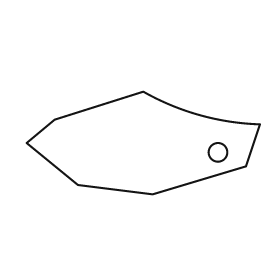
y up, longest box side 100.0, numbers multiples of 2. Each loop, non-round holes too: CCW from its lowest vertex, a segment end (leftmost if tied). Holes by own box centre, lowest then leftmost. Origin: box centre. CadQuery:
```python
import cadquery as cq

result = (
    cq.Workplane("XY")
    .moveTo(4.0, -22.0)
    .lineTo(44.0, -10.0)
    .lineTo(50.0, 8.0)
    .threePointArc((24.0, 12.0), (0.0, 22.0))
    .lineTo(-38.0, 10.0)
    .lineTo(-50.0, 0.0)
    .lineTo(-28.0, -18.0)
    .close()
    .moveTo(32.0, -4.0)
    .circle(4.0)
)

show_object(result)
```